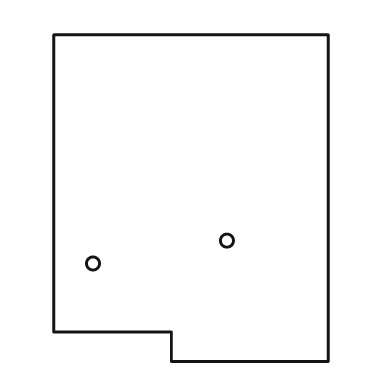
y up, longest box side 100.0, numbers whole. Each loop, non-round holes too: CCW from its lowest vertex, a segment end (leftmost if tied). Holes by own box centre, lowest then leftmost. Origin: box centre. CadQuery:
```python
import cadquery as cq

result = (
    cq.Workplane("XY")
    .moveTo(-6.0, -50.0)
    .lineTo(42.0, -50.0)
    .lineTo(42.0, 50.0)
    .lineTo(-42.0, 50.0)
    .lineTo(-42.0, -41.0)
    .lineTo(-6.0, -41.0)
    .close()
    .moveTo(-30.0, -20.0)
    .circle(2.0)
    .moveTo(11.0, -13.0)
    .circle(2.0)
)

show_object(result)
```